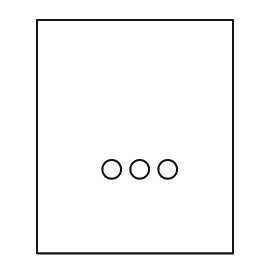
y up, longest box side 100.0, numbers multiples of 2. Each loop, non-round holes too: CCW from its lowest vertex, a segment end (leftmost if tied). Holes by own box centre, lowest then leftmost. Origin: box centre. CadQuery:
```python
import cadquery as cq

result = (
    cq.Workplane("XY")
    .moveTo(-42.0, -50.0)
    .lineTo(42.0, -50.0)
    .lineTo(42.0, 50.0)
    .lineTo(-42.0, 50.0)
    .close()
    .moveTo(-10.0, -14.0)
    .circle(4.0)
    .moveTo(2.0, -14.0)
    .circle(4.0)
    .moveTo(14.0, -14.0)
    .circle(4.0)
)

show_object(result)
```